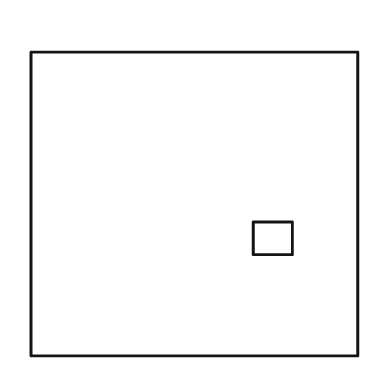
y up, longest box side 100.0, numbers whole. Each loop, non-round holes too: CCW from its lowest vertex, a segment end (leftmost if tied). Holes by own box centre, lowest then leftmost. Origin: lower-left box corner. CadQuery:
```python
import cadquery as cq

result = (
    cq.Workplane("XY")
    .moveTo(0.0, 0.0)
    .lineTo(100.0, 0.0)
    .lineTo(100.0, 93.0)
    .lineTo(0.0, 93.0)
    .close()
    .moveTo(68.0, 31.0)
    .lineTo(80.0, 31.0)
    .lineTo(80.0, 41.0)
    .lineTo(68.0, 41.0)
    .close()
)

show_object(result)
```